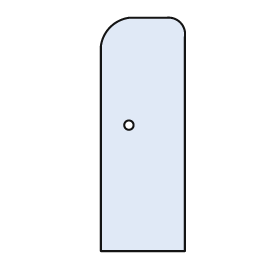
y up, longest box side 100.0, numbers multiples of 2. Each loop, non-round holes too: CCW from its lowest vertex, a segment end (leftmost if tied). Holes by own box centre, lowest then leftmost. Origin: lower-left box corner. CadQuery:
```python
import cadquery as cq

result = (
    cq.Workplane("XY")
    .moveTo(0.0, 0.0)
    .lineTo(36.0, 0.0)
    .lineTo(36.0, 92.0)
    .threePointArc((34.0, 98.0), (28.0, 100.0))
    .lineTo(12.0, 100.0)
    .threePointArc((4.0, 96.0), (0.0, 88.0))
    .close()
    .moveTo(12.0, 54.0)
    .circle(2.0)
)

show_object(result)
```